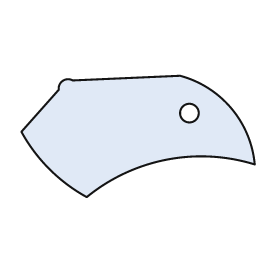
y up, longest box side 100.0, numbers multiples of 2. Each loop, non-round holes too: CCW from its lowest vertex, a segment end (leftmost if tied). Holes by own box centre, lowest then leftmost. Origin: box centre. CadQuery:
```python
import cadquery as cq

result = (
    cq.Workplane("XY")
    .moveTo(-22.0, -26.0)
    .threePointArc((12.0, -10.0), (50.0, -12.0))
    .threePointArc((40.0, 12.0), (18.0, 26.0))
    .lineTo(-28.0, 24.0)
    .threePointArc((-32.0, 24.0), (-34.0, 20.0))
    .lineTo(-50.0, 2.0)
    .threePointArc((-38.0, -14.0), (-22.0, -26.0))
    .close()
    .moveTo(22.0, 10.0)
    .circle(4.0)
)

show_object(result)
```